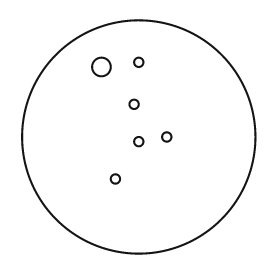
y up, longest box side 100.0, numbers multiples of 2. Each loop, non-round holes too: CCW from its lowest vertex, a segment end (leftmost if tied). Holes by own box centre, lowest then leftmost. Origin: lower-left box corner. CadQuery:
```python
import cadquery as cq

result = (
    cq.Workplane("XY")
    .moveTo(50.0, 50.0)
    .circle(50.0)
    .moveTo(40.0, 32.0)
    .circle(2.0)
    .moveTo(50.0, 48.0)
    .circle(2.0)
    .moveTo(62.0, 50.0)
    .circle(2.0)
    .moveTo(48.0, 64.0)
    .circle(2.0)
    .moveTo(34.0, 80.0)
    .circle(4.0)
    .moveTo(50.0, 82.0)
    .circle(2.0)
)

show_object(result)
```